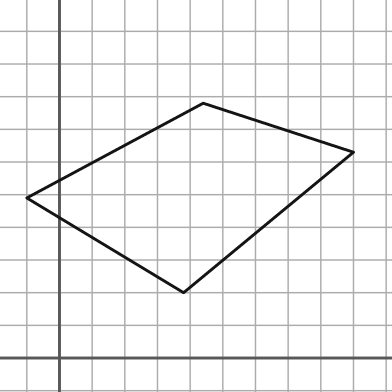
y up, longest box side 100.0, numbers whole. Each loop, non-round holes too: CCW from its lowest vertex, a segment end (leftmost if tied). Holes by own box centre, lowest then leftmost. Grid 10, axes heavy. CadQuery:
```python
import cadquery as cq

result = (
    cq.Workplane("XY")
    .moveTo(38.0, 20.0)
    .lineTo(90.0, 63.0)
    .lineTo(44.0, 78.0)
    .lineTo(-10.0, 49.0)
    .close()
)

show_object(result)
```